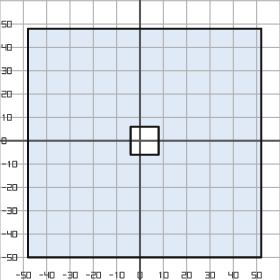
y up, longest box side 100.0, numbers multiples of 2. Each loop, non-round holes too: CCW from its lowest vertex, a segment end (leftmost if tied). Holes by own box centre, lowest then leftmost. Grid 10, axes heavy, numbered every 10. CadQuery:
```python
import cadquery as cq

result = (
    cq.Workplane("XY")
    .moveTo(-48.0, -50.0)
    .lineTo(52.0, -50.0)
    .lineTo(52.0, 48.0)
    .lineTo(-48.0, 48.0)
    .close()
    .moveTo(-4.0, -6.0)
    .lineTo(8.0, -6.0)
    .lineTo(8.0, 6.0)
    .lineTo(-4.0, 6.0)
    .close()
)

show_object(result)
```